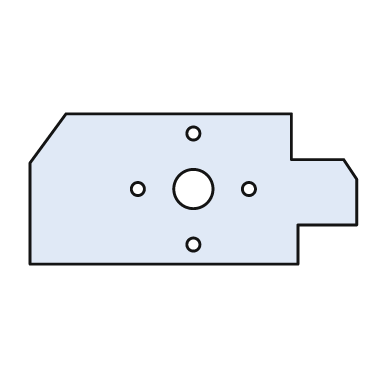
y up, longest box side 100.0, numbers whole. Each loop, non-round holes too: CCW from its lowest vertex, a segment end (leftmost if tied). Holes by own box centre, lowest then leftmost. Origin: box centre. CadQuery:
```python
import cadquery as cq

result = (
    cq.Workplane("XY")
    .moveTo(-50.0, -23.0)
    .lineTo(32.0, -23.0)
    .lineTo(32.0, -11.0)
    .lineTo(50.0, -11.0)
    .lineTo(50.0, 3.0)
    .lineTo(46.0, 9.0)
    .lineTo(30.0, 9.0)
    .lineTo(30.0, 23.0)
    .lineTo(-39.0, 23.0)
    .lineTo(-50.0, 8.0)
    .close()
    .moveTo(0.0, -17.0)
    .circle(2.0)
    .moveTo(-17.0, 0.0)
    .circle(2.0)
    .moveTo(0.0, 0.0)
    .circle(6.0)
    .moveTo(17.0, 0.0)
    .circle(2.0)
    .moveTo(0.0, 17.0)
    .circle(2.0)
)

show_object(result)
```